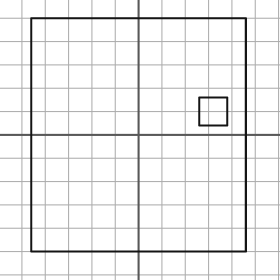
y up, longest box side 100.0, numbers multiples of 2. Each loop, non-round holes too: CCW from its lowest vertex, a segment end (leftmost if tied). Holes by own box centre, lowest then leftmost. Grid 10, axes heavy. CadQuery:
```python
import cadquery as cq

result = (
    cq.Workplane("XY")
    .moveTo(-46.0, -50.0)
    .lineTo(46.0, -50.0)
    .lineTo(46.0, 50.0)
    .lineTo(-46.0, 50.0)
    .close()
    .moveTo(26.0, 4.0)
    .lineTo(38.0, 4.0)
    .lineTo(38.0, 16.0)
    .lineTo(26.0, 16.0)
    .close()
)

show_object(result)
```